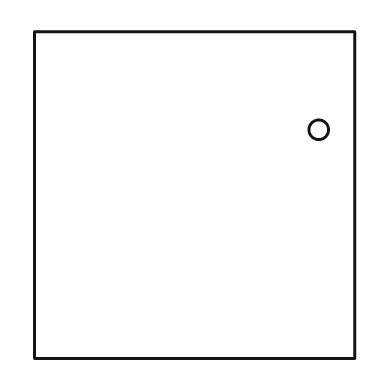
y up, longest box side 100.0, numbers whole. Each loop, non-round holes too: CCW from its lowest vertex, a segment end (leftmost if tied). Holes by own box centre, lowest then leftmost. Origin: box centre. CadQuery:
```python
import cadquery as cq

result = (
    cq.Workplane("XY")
    .moveTo(-49.0, -50.0)
    .lineTo(49.0, -50.0)
    .lineTo(49.0, 50.0)
    .lineTo(-49.0, 50.0)
    .close()
    .moveTo(38.0, 20.0)
    .circle(3.0)
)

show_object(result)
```